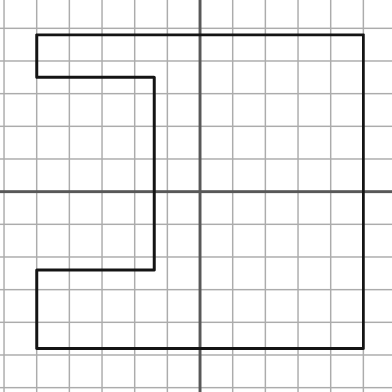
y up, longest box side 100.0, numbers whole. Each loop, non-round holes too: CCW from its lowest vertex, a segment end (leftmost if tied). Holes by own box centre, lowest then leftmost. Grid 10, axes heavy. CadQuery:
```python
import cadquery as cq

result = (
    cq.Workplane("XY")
    .moveTo(-50.0, -48.0)
    .lineTo(50.0, -48.0)
    .lineTo(50.0, 48.0)
    .lineTo(-50.0, 48.0)
    .lineTo(-50.0, 35.0)
    .lineTo(-14.0, 35.0)
    .lineTo(-14.0, -24.0)
    .lineTo(-50.0, -24.0)
    .close()
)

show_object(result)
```